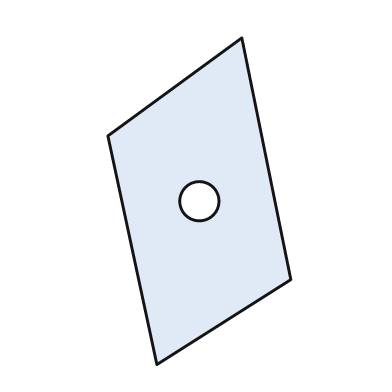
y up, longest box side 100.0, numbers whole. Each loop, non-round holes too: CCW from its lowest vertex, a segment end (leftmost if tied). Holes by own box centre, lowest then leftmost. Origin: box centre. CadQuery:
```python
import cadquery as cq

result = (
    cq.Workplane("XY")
    .moveTo(-13.0, -50.0)
    .lineTo(28.0, -24.0)
    .lineTo(13.0, 50.0)
    .lineTo(-28.0, 20.0)
    .close()
    .moveTo(0.0, 0.0)
    .circle(6.0)
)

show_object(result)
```